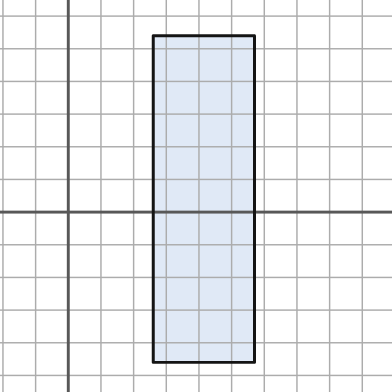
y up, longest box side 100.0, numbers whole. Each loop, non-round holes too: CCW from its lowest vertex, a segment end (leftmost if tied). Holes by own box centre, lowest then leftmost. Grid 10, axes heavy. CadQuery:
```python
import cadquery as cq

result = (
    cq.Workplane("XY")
    .moveTo(26.0, -46.0)
    .lineTo(57.0, -46.0)
    .lineTo(57.0, 54.0)
    .lineTo(26.0, 54.0)
    .close()
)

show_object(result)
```